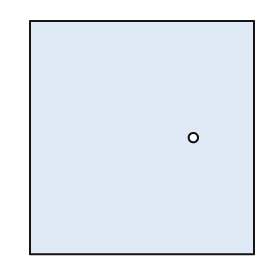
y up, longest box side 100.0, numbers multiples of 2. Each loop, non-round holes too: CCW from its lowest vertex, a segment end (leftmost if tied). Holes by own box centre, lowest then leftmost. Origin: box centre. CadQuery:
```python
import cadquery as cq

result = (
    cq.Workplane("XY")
    .moveTo(-48.0, -50.0)
    .lineTo(48.0, -50.0)
    .lineTo(48.0, 50.0)
    .lineTo(-48.0, 50.0)
    .close()
    .moveTo(22.0, 0.0)
    .circle(2.0)
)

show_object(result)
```